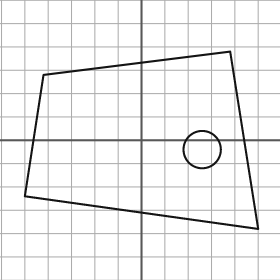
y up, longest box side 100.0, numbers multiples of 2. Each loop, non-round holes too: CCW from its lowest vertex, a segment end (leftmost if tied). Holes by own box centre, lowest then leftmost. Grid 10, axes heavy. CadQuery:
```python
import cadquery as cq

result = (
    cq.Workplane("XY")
    .moveTo(50.0, -38.0)
    .lineTo(38.0, 38.0)
    .lineTo(-42.0, 28.0)
    .lineTo(-50.0, -24.0)
    .close()
    .moveTo(26.0, -4.0)
    .circle(8.0)
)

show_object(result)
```